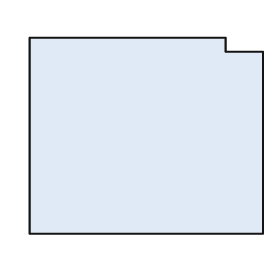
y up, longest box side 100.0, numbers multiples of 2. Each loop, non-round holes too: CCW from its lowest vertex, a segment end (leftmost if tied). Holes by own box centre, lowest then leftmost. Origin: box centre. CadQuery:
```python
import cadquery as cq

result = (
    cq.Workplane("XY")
    .moveTo(-50.0, -42.0)
    .lineTo(50.0, -42.0)
    .lineTo(50.0, 36.0)
    .lineTo(34.0, 36.0)
    .lineTo(34.0, 42.0)
    .lineTo(-50.0, 42.0)
    .close()
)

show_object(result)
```